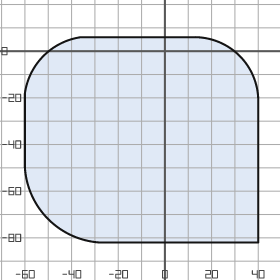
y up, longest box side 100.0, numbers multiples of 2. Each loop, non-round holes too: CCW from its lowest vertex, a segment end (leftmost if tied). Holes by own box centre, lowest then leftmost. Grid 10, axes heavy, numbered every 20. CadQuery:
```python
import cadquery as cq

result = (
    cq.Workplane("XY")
    .moveTo(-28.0, -82.0)
    .lineTo(40.0, -82.0)
    .lineTo(40.0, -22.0)
    .threePointArc((32.0, -2.0), (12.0, 6.0))
    .lineTo(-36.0, 6.0)
    .threePointArc((-52.0, -2.0), (-60.0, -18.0))
    .lineTo(-60.0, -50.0)
    .threePointArc((-50.0, -72.0), (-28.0, -82.0))
    .close()
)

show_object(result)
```